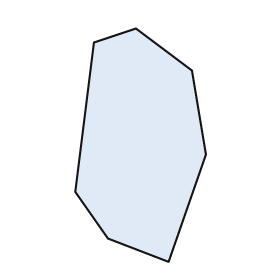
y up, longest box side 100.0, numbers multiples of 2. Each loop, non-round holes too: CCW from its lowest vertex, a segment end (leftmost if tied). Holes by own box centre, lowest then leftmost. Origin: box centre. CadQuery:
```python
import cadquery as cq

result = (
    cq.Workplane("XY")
    .moveTo(12.0, -50.0)
    .lineTo(28.0, -4.0)
    .lineTo(22.0, 32.0)
    .lineTo(-2.0, 50.0)
    .lineTo(-20.0, 44.0)
    .lineTo(-28.0, -20.0)
    .lineTo(-14.0, -40.0)
    .close()
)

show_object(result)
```